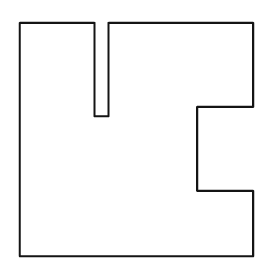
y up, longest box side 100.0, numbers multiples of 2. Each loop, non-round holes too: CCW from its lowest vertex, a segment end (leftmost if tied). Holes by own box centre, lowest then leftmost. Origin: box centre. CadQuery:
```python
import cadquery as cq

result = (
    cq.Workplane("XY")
    .moveTo(-50.0, -50.0)
    .lineTo(50.0, -50.0)
    .lineTo(50.0, -22.0)
    .lineTo(26.0, -22.0)
    .lineTo(26.0, 14.0)
    .lineTo(50.0, 14.0)
    .lineTo(50.0, 50.0)
    .lineTo(-12.0, 50.0)
    .lineTo(-12.0, 10.0)
    .lineTo(-18.0, 10.0)
    .lineTo(-18.0, 50.0)
    .lineTo(-50.0, 50.0)
    .close()
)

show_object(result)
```